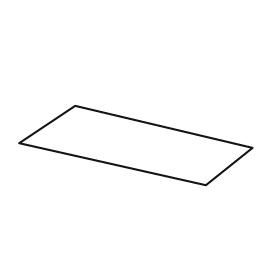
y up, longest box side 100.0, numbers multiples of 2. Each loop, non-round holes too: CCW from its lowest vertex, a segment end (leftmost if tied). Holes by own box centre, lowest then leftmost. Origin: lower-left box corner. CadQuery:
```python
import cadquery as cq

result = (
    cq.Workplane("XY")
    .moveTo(80.0, 0.0)
    .lineTo(100.0, 16.0)
    .lineTo(24.0, 34.0)
    .lineTo(0.0, 18.0)
    .close()
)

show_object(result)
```